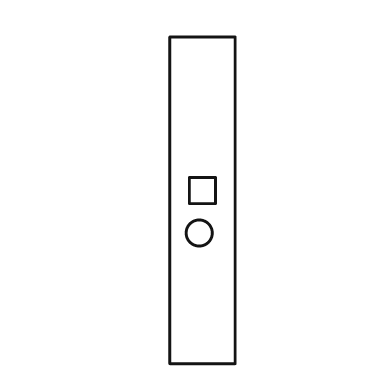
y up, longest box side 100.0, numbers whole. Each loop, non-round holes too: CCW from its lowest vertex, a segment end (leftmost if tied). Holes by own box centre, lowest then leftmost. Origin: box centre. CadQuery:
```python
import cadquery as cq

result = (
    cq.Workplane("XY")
    .moveTo(-10.0, -50.0)
    .lineTo(10.0, -50.0)
    .lineTo(10.0, 50.0)
    .lineTo(-10.0, 50.0)
    .close()
    .moveTo(-1.0, -10.0)
    .circle(4.0)
    .moveTo(-4.0, -1.0)
    .lineTo(4.0, -1.0)
    .lineTo(4.0, 7.0)
    .lineTo(-4.0, 7.0)
    .close()
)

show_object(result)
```